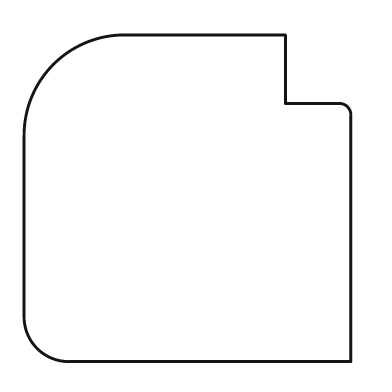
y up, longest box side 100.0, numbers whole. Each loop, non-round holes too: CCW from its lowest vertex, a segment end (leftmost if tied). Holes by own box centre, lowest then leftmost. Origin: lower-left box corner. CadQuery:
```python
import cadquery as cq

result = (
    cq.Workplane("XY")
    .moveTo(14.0, 0.0)
    .lineTo(100.0, 0.0)
    .lineTo(100.0, 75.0)
    .threePointArc((99.0, 78.0), (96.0, 79.0))
    .lineTo(80.0, 79.0)
    .lineTo(80.0, 100.0)
    .lineTo(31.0, 100.0)
    .threePointArc((9.0, 91.0), (0.0, 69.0))
    .lineTo(0.0, 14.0)
    .threePointArc((4.0, 4.0), (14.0, 0.0))
    .close()
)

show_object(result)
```